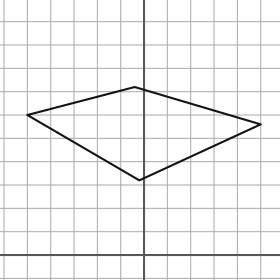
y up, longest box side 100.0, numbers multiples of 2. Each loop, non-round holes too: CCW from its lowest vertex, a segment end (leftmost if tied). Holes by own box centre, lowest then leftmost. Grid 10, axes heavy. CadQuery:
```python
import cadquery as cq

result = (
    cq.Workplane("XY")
    .moveTo(-2.0, 32.0)
    .lineTo(50.0, 56.0)
    .lineTo(-4.0, 72.0)
    .lineTo(-50.0, 60.0)
    .close()
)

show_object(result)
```